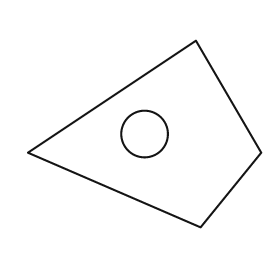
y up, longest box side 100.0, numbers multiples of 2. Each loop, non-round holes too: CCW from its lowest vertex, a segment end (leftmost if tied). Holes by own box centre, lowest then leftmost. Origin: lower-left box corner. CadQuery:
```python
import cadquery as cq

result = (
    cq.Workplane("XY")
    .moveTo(74.0, 0.0)
    .lineTo(100.0, 32.0)
    .lineTo(72.0, 80.0)
    .lineTo(0.0, 32.0)
    .close()
    .moveTo(50.0, 40.0)
    .circle(10.0)
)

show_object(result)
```